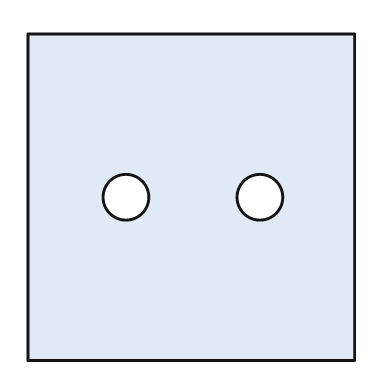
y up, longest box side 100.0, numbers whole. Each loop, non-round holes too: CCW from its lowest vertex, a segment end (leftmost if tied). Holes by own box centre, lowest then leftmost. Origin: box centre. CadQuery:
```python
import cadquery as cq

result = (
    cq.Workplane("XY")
    .moveTo(-50.0, -50.0)
    .lineTo(50.0, -50.0)
    .lineTo(50.0, 50.0)
    .lineTo(-50.0, 50.0)
    .close()
    .moveTo(-20.0, 0.0)
    .circle(7.0)
    .moveTo(21.0, 0.0)
    .circle(7.0)
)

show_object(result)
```